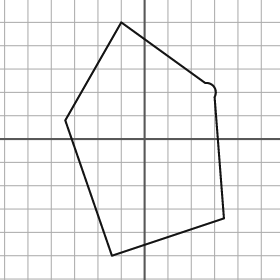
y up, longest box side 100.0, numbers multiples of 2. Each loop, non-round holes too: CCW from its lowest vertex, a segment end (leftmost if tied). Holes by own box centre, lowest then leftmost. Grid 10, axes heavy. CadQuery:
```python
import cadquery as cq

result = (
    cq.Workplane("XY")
    .moveTo(-14.0, -50.0)
    .lineTo(34.0, -34.0)
    .lineTo(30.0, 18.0)
    .threePointArc((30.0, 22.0), (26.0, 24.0))
    .lineTo(-10.0, 50.0)
    .lineTo(-34.0, 8.0)
    .close()
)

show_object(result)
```